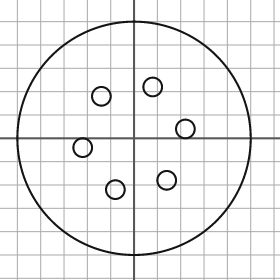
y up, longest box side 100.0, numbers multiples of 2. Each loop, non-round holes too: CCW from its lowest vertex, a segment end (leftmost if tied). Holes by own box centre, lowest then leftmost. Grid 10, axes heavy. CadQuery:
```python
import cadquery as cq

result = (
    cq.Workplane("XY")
    .moveTo(0.0, 0.0)
    .circle(50.0)
    .moveTo(-8.0, -22.0)
    .circle(4.0)
    .moveTo(14.0, -18.0)
    .circle(4.0)
    .moveTo(-22.0, -4.0)
    .circle(4.0)
    .moveTo(22.0, 4.0)
    .circle(4.0)
    .moveTo(-14.0, 18.0)
    .circle(4.0)
    .moveTo(8.0, 22.0)
    .circle(4.0)
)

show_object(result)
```